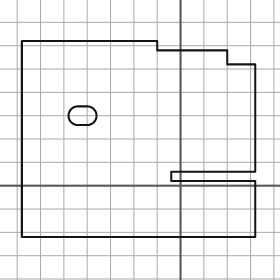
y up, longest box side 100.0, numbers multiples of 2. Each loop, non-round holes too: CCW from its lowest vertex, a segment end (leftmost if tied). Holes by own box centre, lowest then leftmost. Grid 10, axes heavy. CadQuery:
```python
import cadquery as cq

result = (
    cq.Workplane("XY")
    .moveTo(-68.0, -22.0)
    .lineTo(32.0, -22.0)
    .lineTo(32.0, 2.0)
    .lineTo(-4.0, 2.0)
    .lineTo(-4.0, 6.0)
    .lineTo(32.0, 6.0)
    .lineTo(32.0, 52.0)
    .lineTo(20.0, 52.0)
    .lineTo(20.0, 58.0)
    .lineTo(-10.0, 58.0)
    .lineTo(-10.0, 62.0)
    .lineTo(-68.0, 62.0)
    .close()
    .moveTo(-44.0, 26.0)
    .lineTo(-40.0, 26.0)
    .threePointArc((-36.0, 30.0), (-40.0, 34.0))
    .lineTo(-44.0, 34.0)
    .threePointArc((-48.0, 30.0), (-44.0, 26.0))
    .close()
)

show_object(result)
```